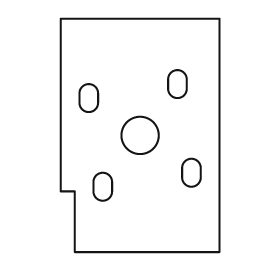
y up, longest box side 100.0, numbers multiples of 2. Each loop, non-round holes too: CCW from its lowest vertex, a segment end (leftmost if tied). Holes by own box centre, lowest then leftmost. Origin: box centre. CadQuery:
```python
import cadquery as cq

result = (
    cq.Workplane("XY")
    .moveTo(-28.0, -50.0)
    .lineTo(34.0, -50.0)
    .lineTo(34.0, 50.0)
    .lineTo(-34.0, 50.0)
    .lineTo(-34.0, -24.0)
    .lineTo(-28.0, -24.0)
    .close()
    .moveTo(-20.0, -24.0)
    .threePointArc((-16.0, -28.0), (-12.0, -24.0))
    .lineTo(-12.0, -20.0)
    .threePointArc((-16.0, -16.0), (-20.0, -20.0))
    .close()
    .moveTo(18.0, -18.0)
    .threePointArc((22.0, -22.0), (26.0, -18.0))
    .lineTo(26.0, -14.0)
    .threePointArc((22.0, -10.0), (18.0, -14.0))
    .close()
    .moveTo(0.0, 0.0)
    .circle(8.0)
    .moveTo(-26.0, 14.0)
    .threePointArc((-22.0, 10.0), (-18.0, 14.0))
    .lineTo(-18.0, 18.0)
    .threePointArc((-22.0, 22.0), (-26.0, 18.0))
    .close()
    .moveTo(12.0, 20.0)
    .threePointArc((16.0, 16.0), (20.0, 20.0))
    .lineTo(20.0, 24.0)
    .threePointArc((16.0, 28.0), (12.0, 24.0))
    .close()
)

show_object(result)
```